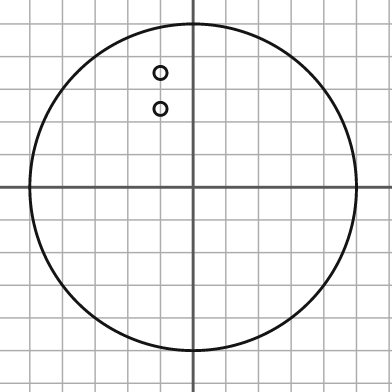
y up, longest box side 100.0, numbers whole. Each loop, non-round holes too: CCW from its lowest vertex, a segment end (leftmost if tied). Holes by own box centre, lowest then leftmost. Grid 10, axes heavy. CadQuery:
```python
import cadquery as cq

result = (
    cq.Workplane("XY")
    .moveTo(0.0, 0.0)
    .circle(50.0)
    .moveTo(-10.0, 24.0)
    .circle(2.0)
    .moveTo(-10.0, 35.0)
    .circle(2.0)
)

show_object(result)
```